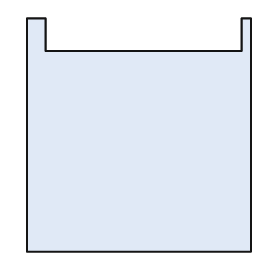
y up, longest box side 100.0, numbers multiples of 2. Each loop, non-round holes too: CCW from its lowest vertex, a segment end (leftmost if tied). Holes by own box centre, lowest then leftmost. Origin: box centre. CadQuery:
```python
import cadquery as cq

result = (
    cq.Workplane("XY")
    .moveTo(-48.0, -50.0)
    .lineTo(48.0, -50.0)
    .lineTo(48.0, 50.0)
    .lineTo(44.0, 50.0)
    .lineTo(44.0, 36.0)
    .lineTo(-40.0, 36.0)
    .lineTo(-40.0, 50.0)
    .lineTo(-48.0, 50.0)
    .close()
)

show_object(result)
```